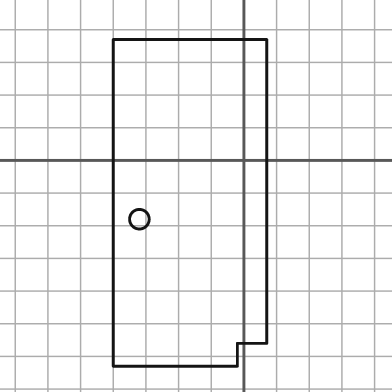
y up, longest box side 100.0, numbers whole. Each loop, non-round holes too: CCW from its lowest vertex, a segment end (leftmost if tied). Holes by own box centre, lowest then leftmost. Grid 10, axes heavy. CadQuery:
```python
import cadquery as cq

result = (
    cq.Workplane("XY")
    .moveTo(-40.0, -63.0)
    .lineTo(-2.0, -63.0)
    .lineTo(-2.0, -56.0)
    .lineTo(7.0, -56.0)
    .lineTo(7.0, 37.0)
    .lineTo(-40.0, 37.0)
    .close()
    .moveTo(-32.0, -18.0)
    .circle(3.0)
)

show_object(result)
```